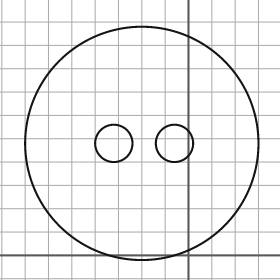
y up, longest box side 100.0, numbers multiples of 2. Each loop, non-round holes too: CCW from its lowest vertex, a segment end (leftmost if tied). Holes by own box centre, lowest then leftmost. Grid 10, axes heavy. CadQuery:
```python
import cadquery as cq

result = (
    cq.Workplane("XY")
    .moveTo(-20.0, 48.0)
    .circle(50.0)
    .moveTo(-32.0, 48.0)
    .circle(8.0)
    .moveTo(-6.0, 48.0)
    .circle(8.0)
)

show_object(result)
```